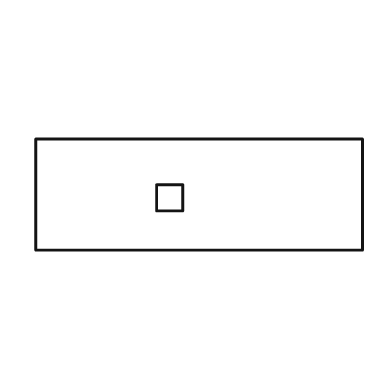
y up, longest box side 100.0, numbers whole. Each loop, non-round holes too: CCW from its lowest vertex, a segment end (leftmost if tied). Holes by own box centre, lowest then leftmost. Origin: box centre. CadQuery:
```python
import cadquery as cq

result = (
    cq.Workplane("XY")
    .moveTo(-50.0, -17.0)
    .lineTo(50.0, -17.0)
    .lineTo(50.0, 17.0)
    .lineTo(-50.0, 17.0)
    .close()
    .moveTo(-13.0, -5.0)
    .lineTo(-5.0, -5.0)
    .lineTo(-5.0, 3.0)
    .lineTo(-13.0, 3.0)
    .close()
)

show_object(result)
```